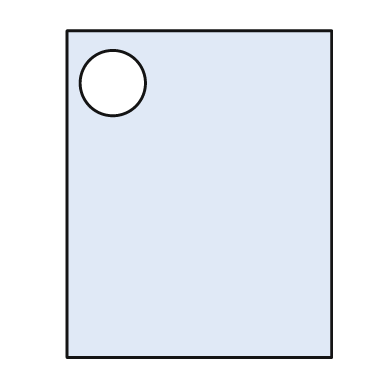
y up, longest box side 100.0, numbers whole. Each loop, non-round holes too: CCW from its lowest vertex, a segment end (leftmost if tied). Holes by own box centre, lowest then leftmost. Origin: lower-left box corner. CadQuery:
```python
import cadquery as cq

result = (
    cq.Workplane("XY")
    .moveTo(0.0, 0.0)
    .lineTo(81.0, 0.0)
    .lineTo(81.0, 100.0)
    .lineTo(0.0, 100.0)
    .close()
    .moveTo(14.0, 84.0)
    .circle(10.0)
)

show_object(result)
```